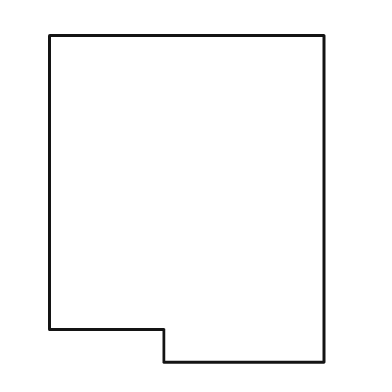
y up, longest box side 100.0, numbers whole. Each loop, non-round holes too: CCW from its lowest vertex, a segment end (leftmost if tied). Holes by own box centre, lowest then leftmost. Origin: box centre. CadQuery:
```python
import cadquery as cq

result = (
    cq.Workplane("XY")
    .moveTo(-7.0, -50.0)
    .lineTo(42.0, -50.0)
    .lineTo(42.0, 50.0)
    .lineTo(-42.0, 50.0)
    .lineTo(-42.0, -40.0)
    .lineTo(-7.0, -40.0)
    .close()
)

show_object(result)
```